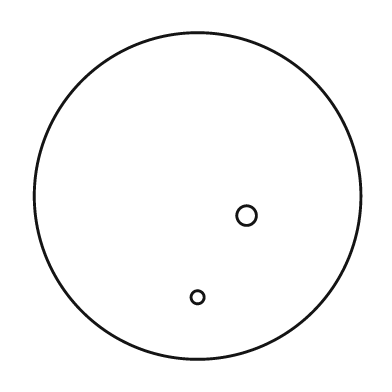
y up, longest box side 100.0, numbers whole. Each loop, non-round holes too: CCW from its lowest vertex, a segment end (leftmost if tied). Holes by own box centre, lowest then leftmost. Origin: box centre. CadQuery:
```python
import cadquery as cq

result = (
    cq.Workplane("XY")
    .moveTo(0.0, 0.0)
    .circle(50.0)
    .moveTo(0.0, -31.0)
    .circle(2.0)
    .moveTo(15.0, -6.0)
    .circle(3.0)
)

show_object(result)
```